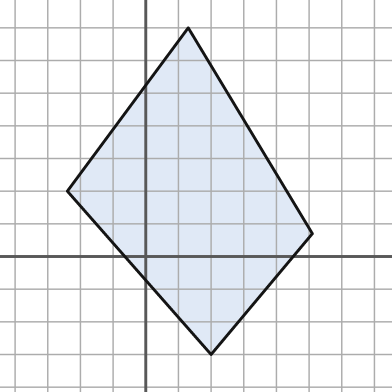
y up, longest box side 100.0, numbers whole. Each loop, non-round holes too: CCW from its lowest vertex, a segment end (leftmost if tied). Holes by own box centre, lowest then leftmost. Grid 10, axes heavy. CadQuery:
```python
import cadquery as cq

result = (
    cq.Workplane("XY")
    .moveTo(20.0, -30.0)
    .lineTo(51.0, 7.0)
    .lineTo(13.0, 70.0)
    .lineTo(-24.0, 20.0)
    .close()
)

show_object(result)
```